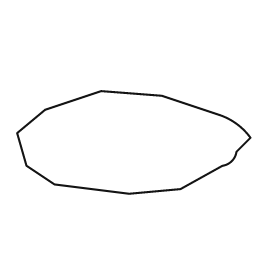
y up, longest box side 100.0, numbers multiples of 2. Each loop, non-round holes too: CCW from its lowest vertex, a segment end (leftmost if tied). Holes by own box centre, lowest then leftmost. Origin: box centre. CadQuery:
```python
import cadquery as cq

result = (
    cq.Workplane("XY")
    .moveTo(-2.0, -22.0)
    .lineTo(20.0, -20.0)
    .lineTo(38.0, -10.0)
    .threePointArc((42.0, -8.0), (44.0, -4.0))
    .lineTo(50.0, 2.0)
    .threePointArc((44.0, 8.0), (36.0, 12.0))
    .lineTo(12.0, 20.0)
    .lineTo(-14.0, 22.0)
    .lineTo(-38.0, 14.0)
    .lineTo(-50.0, 4.0)
    .lineTo(-46.0, -10.0)
    .lineTo(-34.0, -18.0)
    .close()
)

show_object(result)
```